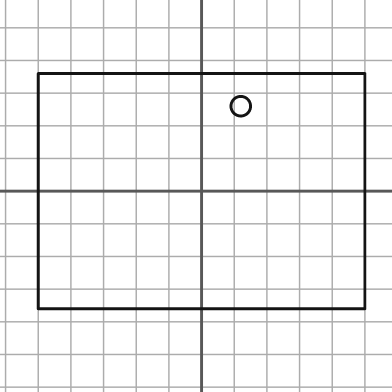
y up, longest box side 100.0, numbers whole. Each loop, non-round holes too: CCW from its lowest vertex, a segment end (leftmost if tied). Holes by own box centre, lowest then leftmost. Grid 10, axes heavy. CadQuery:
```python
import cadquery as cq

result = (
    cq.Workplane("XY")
    .moveTo(-50.0, -36.0)
    .lineTo(50.0, -36.0)
    .lineTo(50.0, 36.0)
    .lineTo(-50.0, 36.0)
    .close()
    .moveTo(12.0, 26.0)
    .circle(3.0)
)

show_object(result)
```